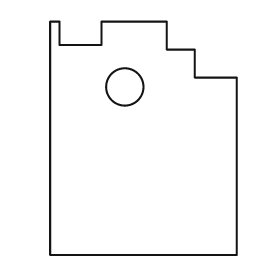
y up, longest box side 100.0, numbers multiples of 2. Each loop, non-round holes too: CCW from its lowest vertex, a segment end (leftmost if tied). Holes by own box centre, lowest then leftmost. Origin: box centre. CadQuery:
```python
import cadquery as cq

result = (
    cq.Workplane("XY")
    .moveTo(-40.0, -50.0)
    .lineTo(40.0, -50.0)
    .lineTo(40.0, 26.0)
    .lineTo(22.0, 26.0)
    .lineTo(22.0, 38.0)
    .lineTo(10.0, 38.0)
    .lineTo(10.0, 50.0)
    .lineTo(-18.0, 50.0)
    .lineTo(-18.0, 40.0)
    .lineTo(-36.0, 40.0)
    .lineTo(-36.0, 50.0)
    .lineTo(-40.0, 50.0)
    .close()
    .moveTo(-8.0, 22.0)
    .circle(8.0)
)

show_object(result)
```